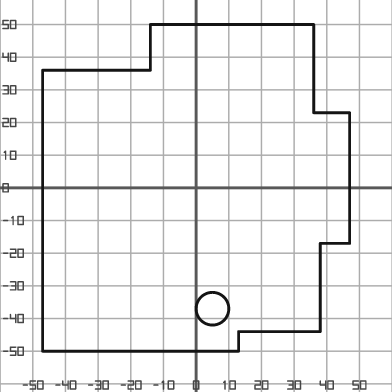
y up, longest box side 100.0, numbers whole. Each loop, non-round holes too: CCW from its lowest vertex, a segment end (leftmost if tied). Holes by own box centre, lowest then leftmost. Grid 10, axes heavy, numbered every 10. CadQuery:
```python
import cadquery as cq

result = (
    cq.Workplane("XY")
    .moveTo(-47.0, -50.0)
    .lineTo(13.0, -50.0)
    .lineTo(13.0, -44.0)
    .lineTo(38.0, -44.0)
    .lineTo(38.0, -17.0)
    .lineTo(47.0, -17.0)
    .lineTo(47.0, 23.0)
    .lineTo(36.0, 23.0)
    .lineTo(36.0, 50.0)
    .lineTo(-14.0, 50.0)
    .lineTo(-14.0, 36.0)
    .lineTo(-47.0, 36.0)
    .close()
    .moveTo(5.0, -37.0)
    .circle(5.0)
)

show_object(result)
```